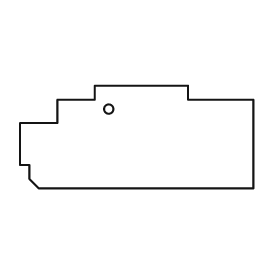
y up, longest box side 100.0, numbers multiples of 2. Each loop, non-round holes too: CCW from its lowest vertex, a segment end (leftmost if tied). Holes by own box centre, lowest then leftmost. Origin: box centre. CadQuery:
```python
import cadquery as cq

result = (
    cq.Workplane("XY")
    .moveTo(-42.0, -22.0)
    .lineTo(50.0, -22.0)
    .lineTo(50.0, 16.0)
    .lineTo(22.0, 16.0)
    .lineTo(22.0, 22.0)
    .lineTo(-18.0, 22.0)
    .lineTo(-18.0, 16.0)
    .lineTo(-34.0, 16.0)
    .lineTo(-34.0, 6.0)
    .lineTo(-50.0, 6.0)
    .lineTo(-50.0, -12.0)
    .lineTo(-46.0, -12.0)
    .lineTo(-46.0, -18.0)
    .close()
    .moveTo(-12.0, 12.0)
    .circle(2.0)
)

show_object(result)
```